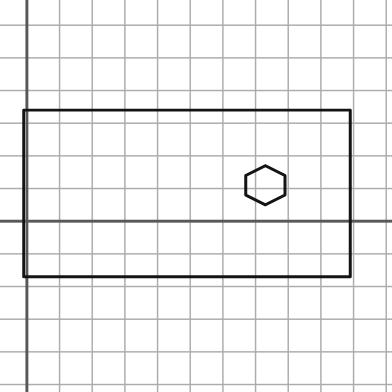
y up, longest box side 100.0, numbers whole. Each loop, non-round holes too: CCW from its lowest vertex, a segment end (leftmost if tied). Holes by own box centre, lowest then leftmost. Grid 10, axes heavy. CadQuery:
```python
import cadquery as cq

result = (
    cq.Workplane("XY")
    .moveTo(-1.0, -17.0)
    .lineTo(99.0, -17.0)
    .lineTo(99.0, 34.0)
    .lineTo(-1.0, 34.0)
    .close()
    .moveTo(73.0, 5.0)
    .lineTo(79.0, 8.0)
    .lineTo(79.0, 14.0)
    .lineTo(73.0, 17.0)
    .lineTo(67.0, 14.0)
    .lineTo(67.0, 8.0)
    .close()
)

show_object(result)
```